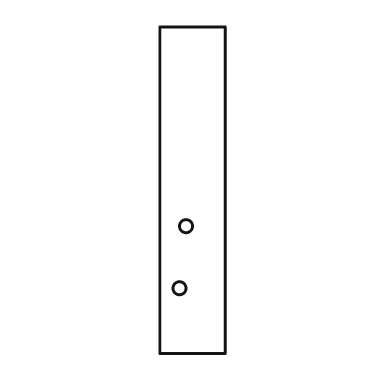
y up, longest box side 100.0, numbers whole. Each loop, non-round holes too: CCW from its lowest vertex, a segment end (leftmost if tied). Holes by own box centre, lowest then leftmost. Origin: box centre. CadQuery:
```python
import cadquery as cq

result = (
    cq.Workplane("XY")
    .moveTo(-10.0, -50.0)
    .lineTo(10.0, -50.0)
    .lineTo(10.0, 50.0)
    .lineTo(-10.0, 50.0)
    .close()
    .moveTo(-4.0, -30.0)
    .circle(2.0)
    .moveTo(-2.0, -11.0)
    .circle(2.0)
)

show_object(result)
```